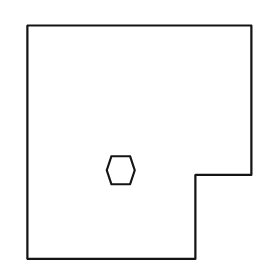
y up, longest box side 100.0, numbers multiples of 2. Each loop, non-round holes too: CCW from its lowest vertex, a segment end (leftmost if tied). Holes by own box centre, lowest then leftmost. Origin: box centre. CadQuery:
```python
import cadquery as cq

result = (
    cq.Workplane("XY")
    .moveTo(-48.0, -50.0)
    .lineTo(24.0, -50.0)
    .lineTo(24.0, -14.0)
    .lineTo(48.0, -14.0)
    .lineTo(48.0, 50.0)
    .lineTo(-48.0, 50.0)
    .close()
    .moveTo(-12.0, -18.0)
    .lineTo(-4.0, -18.0)
    .lineTo(-2.0, -12.0)
    .lineTo(-4.0, -6.0)
    .lineTo(-12.0, -6.0)
    .lineTo(-14.0, -12.0)
    .close()
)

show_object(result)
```